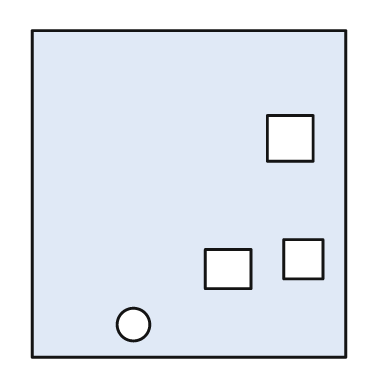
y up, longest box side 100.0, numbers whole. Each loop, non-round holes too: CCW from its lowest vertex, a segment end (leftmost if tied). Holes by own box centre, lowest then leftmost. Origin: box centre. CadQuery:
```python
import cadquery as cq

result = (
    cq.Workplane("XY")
    .moveTo(-48.0, -50.0)
    .lineTo(48.0, -50.0)
    .lineTo(48.0, 50.0)
    .lineTo(-48.0, 50.0)
    .close()
    .moveTo(-17.0, -40.0)
    .circle(5.0)
    .moveTo(5.0, -29.0)
    .lineTo(19.0, -29.0)
    .lineTo(19.0, -17.0)
    .lineTo(5.0, -17.0)
    .close()
    .moveTo(29.0, -26.0)
    .lineTo(41.0, -26.0)
    .lineTo(41.0, -14.0)
    .lineTo(29.0, -14.0)
    .close()
    .moveTo(24.0, 10.0)
    .lineTo(38.0, 10.0)
    .lineTo(38.0, 24.0)
    .lineTo(24.0, 24.0)
    .close()
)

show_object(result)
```